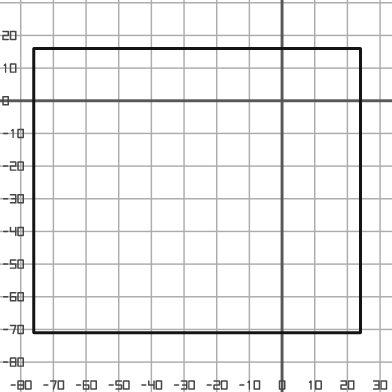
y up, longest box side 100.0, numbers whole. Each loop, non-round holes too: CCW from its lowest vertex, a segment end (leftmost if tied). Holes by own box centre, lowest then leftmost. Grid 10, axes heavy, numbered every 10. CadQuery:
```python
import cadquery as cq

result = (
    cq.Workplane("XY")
    .moveTo(-76.0, -71.0)
    .lineTo(24.0, -71.0)
    .lineTo(24.0, 16.0)
    .lineTo(-76.0, 16.0)
    .close()
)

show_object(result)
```